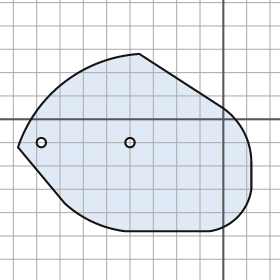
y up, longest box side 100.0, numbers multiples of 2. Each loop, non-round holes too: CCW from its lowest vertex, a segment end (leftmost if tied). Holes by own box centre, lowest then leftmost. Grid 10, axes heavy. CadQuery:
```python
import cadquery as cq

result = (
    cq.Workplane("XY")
    .moveTo(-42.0, -48.0)
    .lineTo(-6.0, -48.0)
    .threePointArc((6.0, -42.0), (12.0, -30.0))
    .lineTo(12.0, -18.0)
    .threePointArc((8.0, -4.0), (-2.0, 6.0))
    .lineTo(-36.0, 28.0)
    .threePointArc((-68.0, 16.0), (-88.0, -12.0))
    .lineTo(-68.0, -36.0)
    .threePointArc((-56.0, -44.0), (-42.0, -48.0))
    .close()
    .moveTo(-78.0, -10.0)
    .circle(2.0)
    .moveTo(-40.0, -10.0)
    .circle(2.0)
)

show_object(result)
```